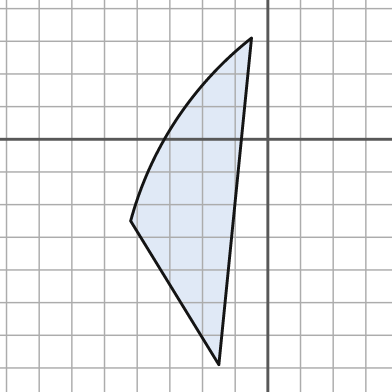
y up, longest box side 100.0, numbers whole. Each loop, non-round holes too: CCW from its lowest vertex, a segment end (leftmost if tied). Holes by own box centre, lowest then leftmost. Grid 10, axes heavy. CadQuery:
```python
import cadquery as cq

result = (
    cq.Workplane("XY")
    .moveTo(-15.0, -69.0)
    .lineTo(-5.0, 31.0)
    .threePointArc((-28.0, 6.0), (-42.0, -25.0))
    .close()
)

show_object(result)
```